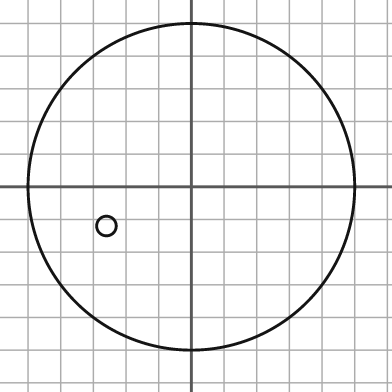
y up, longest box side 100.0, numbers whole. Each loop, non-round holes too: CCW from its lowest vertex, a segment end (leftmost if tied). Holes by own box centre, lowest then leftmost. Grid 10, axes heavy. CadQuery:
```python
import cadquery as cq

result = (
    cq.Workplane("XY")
    .moveTo(0.0, 0.0)
    .circle(50.0)
    .moveTo(-26.0, -12.0)
    .circle(3.0)
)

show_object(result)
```